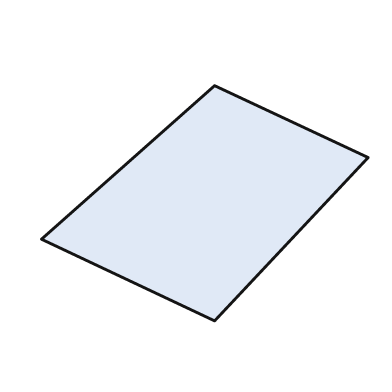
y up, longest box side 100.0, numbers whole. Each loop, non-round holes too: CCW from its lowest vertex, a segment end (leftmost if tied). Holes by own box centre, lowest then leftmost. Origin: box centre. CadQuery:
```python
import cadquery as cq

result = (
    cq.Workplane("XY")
    .moveTo(3.0, -36.0)
    .lineTo(50.0, 14.0)
    .lineTo(3.0, 36.0)
    .lineTo(-50.0, -11.0)
    .close()
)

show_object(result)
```